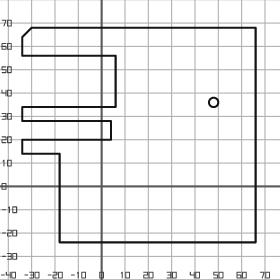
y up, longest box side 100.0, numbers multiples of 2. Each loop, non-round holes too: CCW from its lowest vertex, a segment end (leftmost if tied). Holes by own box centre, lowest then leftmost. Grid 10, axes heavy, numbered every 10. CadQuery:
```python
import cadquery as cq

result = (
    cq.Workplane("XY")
    .moveTo(-18.0, -24.0)
    .lineTo(66.0, -24.0)
    .lineTo(66.0, 68.0)
    .lineTo(-30.0, 68.0)
    .lineTo(-34.0, 64.0)
    .lineTo(-34.0, 56.0)
    .lineTo(6.0, 56.0)
    .lineTo(6.0, 34.0)
    .lineTo(-34.0, 34.0)
    .lineTo(-34.0, 28.0)
    .lineTo(4.0, 28.0)
    .lineTo(4.0, 20.0)
    .lineTo(-34.0, 20.0)
    .lineTo(-34.0, 14.0)
    .lineTo(-18.0, 14.0)
    .close()
    .moveTo(48.0, 36.0)
    .circle(2.0)
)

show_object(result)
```